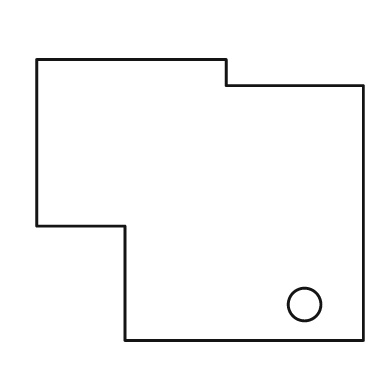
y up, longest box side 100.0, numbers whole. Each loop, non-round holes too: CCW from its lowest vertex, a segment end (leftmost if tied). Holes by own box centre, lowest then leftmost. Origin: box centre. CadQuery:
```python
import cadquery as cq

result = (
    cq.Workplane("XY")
    .moveTo(-23.0, -43.0)
    .lineTo(50.0, -43.0)
    .lineTo(50.0, 35.0)
    .lineTo(8.0, 35.0)
    .lineTo(8.0, 43.0)
    .lineTo(-50.0, 43.0)
    .lineTo(-50.0, -8.0)
    .lineTo(-23.0, -8.0)
    .close()
    .moveTo(32.0, -32.0)
    .circle(5.0)
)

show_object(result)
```